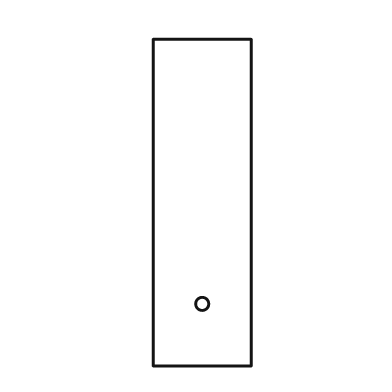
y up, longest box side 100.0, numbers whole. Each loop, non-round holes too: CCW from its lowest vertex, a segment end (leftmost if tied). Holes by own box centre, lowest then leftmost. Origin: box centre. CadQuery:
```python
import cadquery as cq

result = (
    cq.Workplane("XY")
    .moveTo(-15.0, -50.0)
    .lineTo(15.0, -50.0)
    .lineTo(15.0, 50.0)
    .lineTo(-15.0, 50.0)
    .close()
    .moveTo(0.0, -31.0)
    .circle(2.0)
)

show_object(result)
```